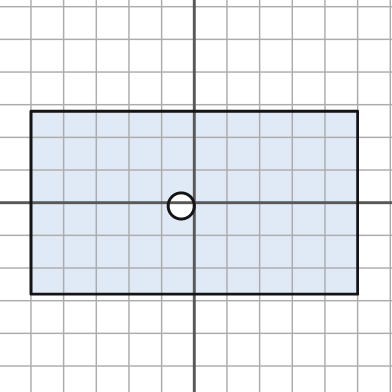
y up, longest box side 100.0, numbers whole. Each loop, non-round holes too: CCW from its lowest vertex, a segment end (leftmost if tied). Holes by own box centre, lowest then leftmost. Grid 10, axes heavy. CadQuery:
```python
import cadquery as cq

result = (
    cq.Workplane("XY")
    .moveTo(-50.0, -28.0)
    .lineTo(50.0, -28.0)
    .lineTo(50.0, 28.0)
    .lineTo(-50.0, 28.0)
    .close()
    .moveTo(-4.0, -1.0)
    .circle(4.0)
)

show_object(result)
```